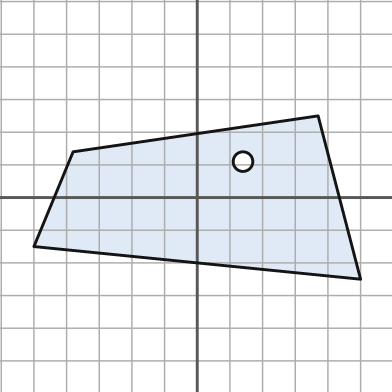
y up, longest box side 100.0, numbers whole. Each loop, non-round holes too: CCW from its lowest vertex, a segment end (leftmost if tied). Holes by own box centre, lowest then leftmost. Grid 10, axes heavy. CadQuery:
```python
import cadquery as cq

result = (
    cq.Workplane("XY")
    .moveTo(50.0, -25.0)
    .lineTo(37.0, 25.0)
    .lineTo(-38.0, 14.0)
    .lineTo(-50.0, -15.0)
    .close()
    .moveTo(14.0, 11.0)
    .circle(3.0)
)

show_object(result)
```